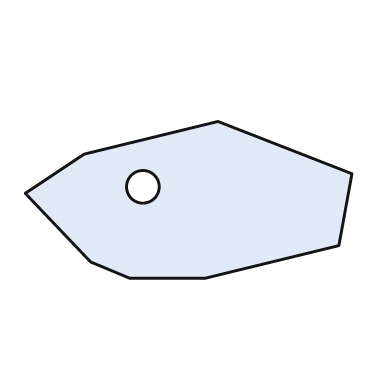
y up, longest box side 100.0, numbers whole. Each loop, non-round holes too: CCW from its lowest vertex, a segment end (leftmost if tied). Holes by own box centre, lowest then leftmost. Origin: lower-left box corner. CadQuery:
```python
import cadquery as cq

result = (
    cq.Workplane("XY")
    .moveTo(32.0, 0.0)
    .lineTo(55.0, 0.0)
    .lineTo(96.0, 10.0)
    .lineTo(100.0, 32.0)
    .lineTo(59.0, 48.0)
    .lineTo(18.0, 38.0)
    .lineTo(0.0, 26.0)
    .lineTo(20.0, 5.0)
    .close()
    .moveTo(36.0, 28.0)
    .circle(5.0)
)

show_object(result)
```